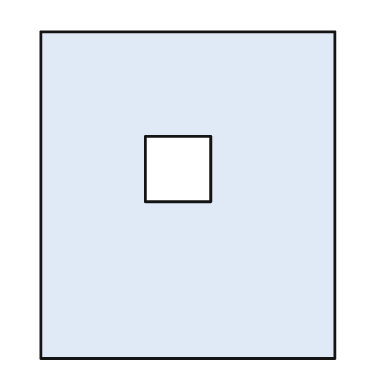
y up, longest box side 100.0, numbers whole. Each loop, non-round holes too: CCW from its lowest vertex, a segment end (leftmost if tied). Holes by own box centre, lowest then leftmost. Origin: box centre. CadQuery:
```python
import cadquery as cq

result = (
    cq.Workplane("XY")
    .moveTo(-45.0, -50.0)
    .lineTo(45.0, -50.0)
    .lineTo(45.0, 50.0)
    .lineTo(-45.0, 50.0)
    .close()
    .moveTo(-13.0, -2.0)
    .lineTo(7.0, -2.0)
    .lineTo(7.0, 18.0)
    .lineTo(-13.0, 18.0)
    .close()
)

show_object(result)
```